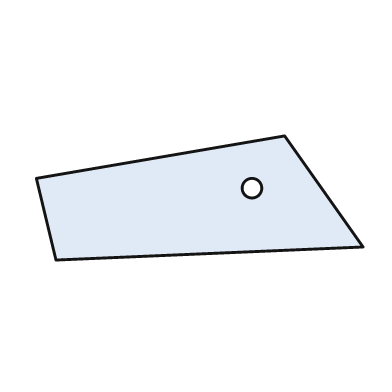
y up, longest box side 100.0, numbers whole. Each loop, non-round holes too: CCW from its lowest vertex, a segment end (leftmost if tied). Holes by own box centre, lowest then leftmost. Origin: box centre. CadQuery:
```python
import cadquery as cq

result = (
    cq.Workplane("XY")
    .moveTo(-44.0, -19.0)
    .lineTo(50.0, -15.0)
    .lineTo(26.0, 19.0)
    .lineTo(-50.0, 6.0)
    .close()
    .moveTo(16.0, 3.0)
    .circle(3.0)
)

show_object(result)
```